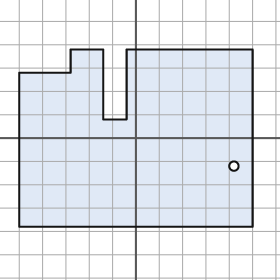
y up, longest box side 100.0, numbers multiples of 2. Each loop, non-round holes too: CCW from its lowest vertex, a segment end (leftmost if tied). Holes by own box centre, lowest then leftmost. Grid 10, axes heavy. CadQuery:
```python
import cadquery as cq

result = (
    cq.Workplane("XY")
    .moveTo(-50.0, -38.0)
    .lineTo(50.0, -38.0)
    .lineTo(50.0, 38.0)
    .lineTo(-4.0, 38.0)
    .lineTo(-4.0, 8.0)
    .lineTo(-14.0, 8.0)
    .lineTo(-14.0, 38.0)
    .lineTo(-28.0, 38.0)
    .lineTo(-28.0, 28.0)
    .lineTo(-50.0, 28.0)
    .close()
    .moveTo(42.0, -12.0)
    .circle(2.0)
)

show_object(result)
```